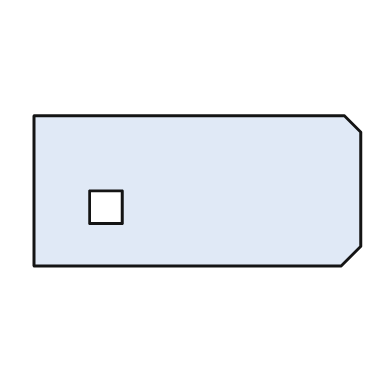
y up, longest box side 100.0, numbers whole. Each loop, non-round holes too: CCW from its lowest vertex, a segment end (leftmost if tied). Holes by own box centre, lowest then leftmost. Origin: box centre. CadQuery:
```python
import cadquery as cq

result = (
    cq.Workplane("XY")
    .moveTo(-50.0, -23.0)
    .lineTo(44.0, -23.0)
    .lineTo(50.0, -17.0)
    .lineTo(50.0, 18.0)
    .lineTo(45.0, 23.0)
    .lineTo(-50.0, 23.0)
    .close()
    .moveTo(-33.0, -10.0)
    .lineTo(-23.0, -10.0)
    .lineTo(-23.0, 0.0)
    .lineTo(-33.0, 0.0)
    .close()
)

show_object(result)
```